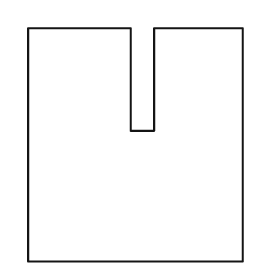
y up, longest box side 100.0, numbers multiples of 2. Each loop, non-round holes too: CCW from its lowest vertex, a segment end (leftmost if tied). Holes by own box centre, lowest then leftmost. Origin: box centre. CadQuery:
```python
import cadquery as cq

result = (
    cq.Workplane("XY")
    .moveTo(-46.0, -50.0)
    .lineTo(46.0, -50.0)
    .lineTo(46.0, 50.0)
    .lineTo(8.0, 50.0)
    .lineTo(8.0, 6.0)
    .lineTo(-2.0, 6.0)
    .lineTo(-2.0, 50.0)
    .lineTo(-46.0, 50.0)
    .close()
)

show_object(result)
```